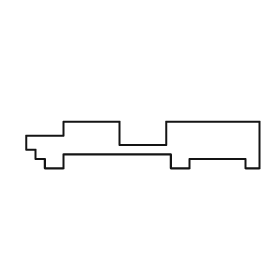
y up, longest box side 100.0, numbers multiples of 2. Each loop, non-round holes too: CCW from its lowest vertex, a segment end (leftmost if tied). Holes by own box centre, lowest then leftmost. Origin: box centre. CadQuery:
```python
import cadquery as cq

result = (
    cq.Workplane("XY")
    .moveTo(-42.0, -10.0)
    .lineTo(-34.0, -10.0)
    .lineTo(-34.0, -4.0)
    .lineTo(12.0, -4.0)
    .lineTo(12.0, -10.0)
    .lineTo(20.0, -10.0)
    .lineTo(20.0, -6.0)
    .lineTo(44.0, -6.0)
    .lineTo(44.0, -10.0)
    .lineTo(50.0, -10.0)
    .lineTo(50.0, 10.0)
    .lineTo(10.0, 10.0)
    .lineTo(10.0, 0.0)
    .lineTo(-10.0, 0.0)
    .lineTo(-10.0, 10.0)
    .lineTo(-34.0, 10.0)
    .lineTo(-34.0, 4.0)
    .lineTo(-50.0, 4.0)
    .lineTo(-50.0, -2.0)
    .lineTo(-46.0, -2.0)
    .lineTo(-46.0, -6.0)
    .lineTo(-42.0, -6.0)
    .close()
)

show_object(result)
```